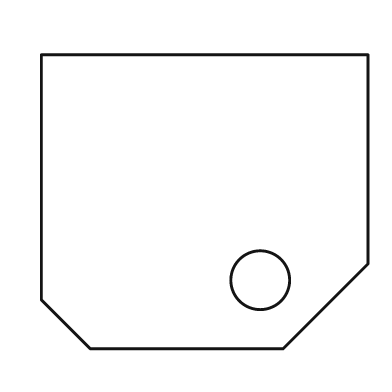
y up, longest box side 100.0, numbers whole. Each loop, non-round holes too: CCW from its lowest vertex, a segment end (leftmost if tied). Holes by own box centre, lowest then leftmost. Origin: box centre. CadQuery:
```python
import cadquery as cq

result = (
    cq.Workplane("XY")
    .moveTo(-35.0, -45.0)
    .lineTo(24.0, -45.0)
    .lineTo(50.0, -19.0)
    .lineTo(50.0, 45.0)
    .lineTo(-50.0, 45.0)
    .lineTo(-50.0, -30.0)
    .close()
    .moveTo(17.0, -24.0)
    .circle(9.0)
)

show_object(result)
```